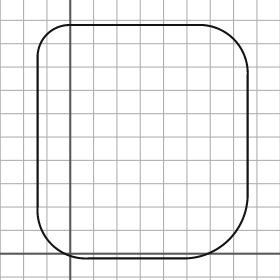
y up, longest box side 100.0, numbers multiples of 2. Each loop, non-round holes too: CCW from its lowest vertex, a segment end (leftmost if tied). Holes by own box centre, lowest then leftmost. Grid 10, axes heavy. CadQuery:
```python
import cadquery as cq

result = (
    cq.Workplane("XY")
    .moveTo(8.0, -2.0)
    .lineTo(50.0, -2.0)
    .threePointArc((68.0, 6.0), (76.0, 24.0))
    .lineTo(76.0, 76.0)
    .threePointArc((70.0, 92.0), (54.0, 98.0))
    .lineTo(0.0, 98.0)
    .threePointArc((-10.0, 94.0), (-14.0, 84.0))
    .lineTo(-14.0, 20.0)
    .threePointArc((-8.0, 4.0), (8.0, -2.0))
    .close()
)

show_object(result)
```